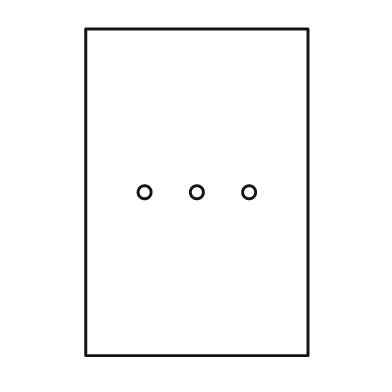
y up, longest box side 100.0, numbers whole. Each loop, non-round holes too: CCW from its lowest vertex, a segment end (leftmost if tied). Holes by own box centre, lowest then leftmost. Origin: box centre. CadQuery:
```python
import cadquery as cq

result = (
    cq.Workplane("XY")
    .moveTo(-34.0, -50.0)
    .lineTo(34.0, -50.0)
    .lineTo(34.0, 50.0)
    .lineTo(-34.0, 50.0)
    .close()
    .moveTo(-16.0, 0.0)
    .circle(2.0)
    .moveTo(0.0, 0.0)
    .circle(2.0)
    .moveTo(16.0, 0.0)
    .circle(2.0)
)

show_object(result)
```